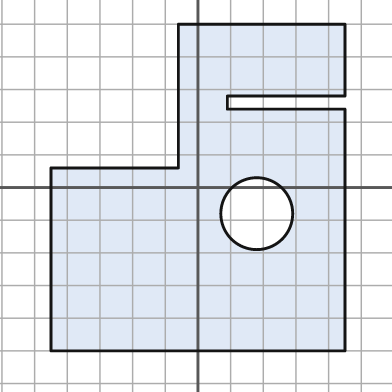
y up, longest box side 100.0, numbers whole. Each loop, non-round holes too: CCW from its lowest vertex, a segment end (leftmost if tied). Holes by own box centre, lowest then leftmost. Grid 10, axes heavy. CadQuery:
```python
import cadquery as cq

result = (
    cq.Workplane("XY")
    .moveTo(-45.0, -50.0)
    .lineTo(45.0, -50.0)
    .lineTo(45.0, 24.0)
    .lineTo(9.0, 24.0)
    .lineTo(9.0, 28.0)
    .lineTo(45.0, 28.0)
    .lineTo(45.0, 50.0)
    .lineTo(-6.0, 50.0)
    .lineTo(-6.0, 6.0)
    .lineTo(-45.0, 6.0)
    .close()
    .moveTo(18.0, -8.0)
    .circle(11.0)
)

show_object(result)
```